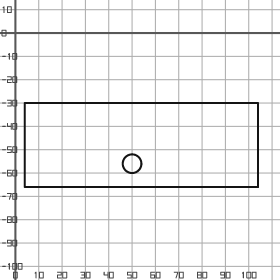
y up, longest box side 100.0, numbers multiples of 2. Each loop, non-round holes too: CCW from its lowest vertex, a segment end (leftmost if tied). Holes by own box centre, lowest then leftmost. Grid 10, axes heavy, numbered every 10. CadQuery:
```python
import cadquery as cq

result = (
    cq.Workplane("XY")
    .moveTo(4.0, -66.0)
    .lineTo(104.0, -66.0)
    .lineTo(104.0, -30.0)
    .lineTo(4.0, -30.0)
    .close()
    .moveTo(50.0, -56.0)
    .circle(4.0)
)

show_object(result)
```